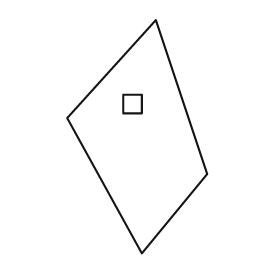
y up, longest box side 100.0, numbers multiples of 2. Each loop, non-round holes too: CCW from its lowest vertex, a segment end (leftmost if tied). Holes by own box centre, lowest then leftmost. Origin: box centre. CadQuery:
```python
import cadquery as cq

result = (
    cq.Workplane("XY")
    .moveTo(2.0, -50.0)
    .lineTo(30.0, -16.0)
    .lineTo(8.0, 50.0)
    .lineTo(-30.0, 8.0)
    .close()
    .moveTo(-6.0, 10.0)
    .lineTo(2.0, 10.0)
    .lineTo(2.0, 18.0)
    .lineTo(-6.0, 18.0)
    .close()
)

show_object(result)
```